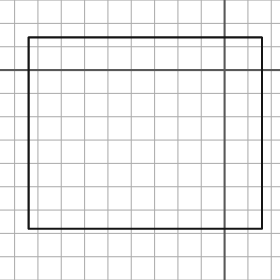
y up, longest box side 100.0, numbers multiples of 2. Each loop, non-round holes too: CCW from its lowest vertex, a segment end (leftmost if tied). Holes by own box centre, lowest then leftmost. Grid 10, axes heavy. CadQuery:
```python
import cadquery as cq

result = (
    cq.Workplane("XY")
    .moveTo(-84.0, -68.0)
    .lineTo(16.0, -68.0)
    .lineTo(16.0, 14.0)
    .lineTo(-84.0, 14.0)
    .close()
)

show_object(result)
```